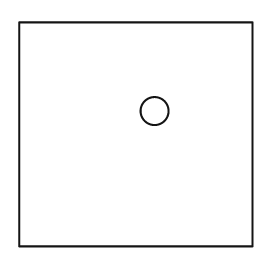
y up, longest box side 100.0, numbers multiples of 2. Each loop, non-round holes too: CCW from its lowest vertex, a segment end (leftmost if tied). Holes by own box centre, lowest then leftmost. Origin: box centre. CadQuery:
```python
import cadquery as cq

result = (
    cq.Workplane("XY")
    .moveTo(-50.0, -48.0)
    .lineTo(50.0, -48.0)
    .lineTo(50.0, 48.0)
    .lineTo(-50.0, 48.0)
    .close()
    .moveTo(8.0, 10.0)
    .circle(6.0)
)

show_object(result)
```